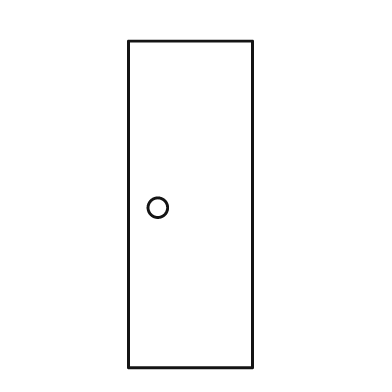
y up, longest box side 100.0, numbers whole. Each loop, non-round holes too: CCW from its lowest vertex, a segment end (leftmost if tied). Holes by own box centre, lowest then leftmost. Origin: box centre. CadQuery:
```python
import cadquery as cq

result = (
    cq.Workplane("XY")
    .moveTo(-19.0, -50.0)
    .lineTo(19.0, -50.0)
    .lineTo(19.0, 50.0)
    .lineTo(-19.0, 50.0)
    .close()
    .moveTo(-10.0, -1.0)
    .circle(3.0)
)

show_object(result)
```